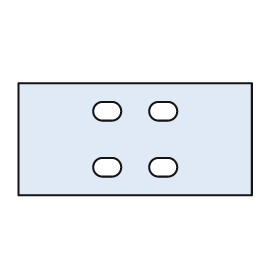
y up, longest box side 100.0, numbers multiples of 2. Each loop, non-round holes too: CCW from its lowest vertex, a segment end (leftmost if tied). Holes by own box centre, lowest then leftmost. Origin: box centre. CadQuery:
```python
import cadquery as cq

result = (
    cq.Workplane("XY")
    .moveTo(-50.0, -24.0)
    .lineTo(50.0, -24.0)
    .lineTo(50.0, 24.0)
    .lineTo(-50.0, 24.0)
    .close()
    .moveTo(-14.0, -16.0)
    .lineTo(-10.0, -16.0)
    .threePointArc((-6.0, -12.0), (-10.0, -8.0))
    .lineTo(-14.0, -8.0)
    .threePointArc((-18.0, -12.0), (-14.0, -16.0))
    .close()
    .moveTo(10.0, -16.0)
    .lineTo(14.0, -16.0)
    .threePointArc((18.0, -12.0), (14.0, -8.0))
    .lineTo(10.0, -8.0)
    .threePointArc((6.0, -12.0), (10.0, -16.0))
    .close()
    .moveTo(-14.0, 8.0)
    .lineTo(-10.0, 8.0)
    .threePointArc((-6.0, 12.0), (-10.0, 16.0))
    .lineTo(-14.0, 16.0)
    .threePointArc((-18.0, 12.0), (-14.0, 8.0))
    .close()
    .moveTo(10.0, 8.0)
    .lineTo(14.0, 8.0)
    .threePointArc((18.0, 12.0), (14.0, 16.0))
    .lineTo(10.0, 16.0)
    .threePointArc((6.0, 12.0), (10.0, 8.0))
    .close()
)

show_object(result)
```